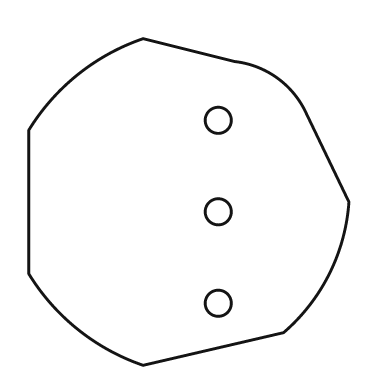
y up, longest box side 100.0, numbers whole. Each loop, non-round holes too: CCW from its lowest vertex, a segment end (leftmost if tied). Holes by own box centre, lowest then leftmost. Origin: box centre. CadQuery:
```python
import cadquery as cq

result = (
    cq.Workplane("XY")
    .moveTo(-14.0, -50.0)
    .lineTo(29.0, -40.0)
    .threePointArc((43.0, -22.0), (49.0, 0.0))
    .lineTo(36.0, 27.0)
    .threePointArc((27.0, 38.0), (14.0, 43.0))
    .lineTo(-14.0, 50.0)
    .threePointArc((-34.0, 39.0), (-49.0, 22.0))
    .lineTo(-49.0, -22.0)
    .threePointArc((-34.0, -39.0), (-14.0, -50.0))
    .close()
    .moveTo(9.0, -31.0)
    .circle(4.0)
    .moveTo(9.0, -3.0)
    .circle(4.0)
    .moveTo(9.0, 25.0)
    .circle(4.0)
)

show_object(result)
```